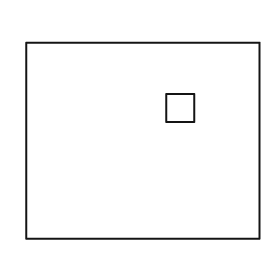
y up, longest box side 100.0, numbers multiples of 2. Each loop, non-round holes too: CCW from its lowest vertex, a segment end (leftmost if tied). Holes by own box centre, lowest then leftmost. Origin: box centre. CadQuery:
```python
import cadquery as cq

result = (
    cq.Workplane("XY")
    .moveTo(-50.0, -42.0)
    .lineTo(50.0, -42.0)
    .lineTo(50.0, 42.0)
    .lineTo(-50.0, 42.0)
    .close()
    .moveTo(10.0, 8.0)
    .lineTo(22.0, 8.0)
    .lineTo(22.0, 20.0)
    .lineTo(10.0, 20.0)
    .close()
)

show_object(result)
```